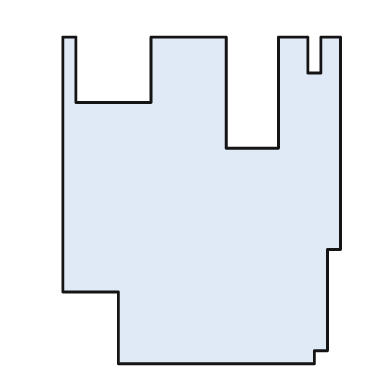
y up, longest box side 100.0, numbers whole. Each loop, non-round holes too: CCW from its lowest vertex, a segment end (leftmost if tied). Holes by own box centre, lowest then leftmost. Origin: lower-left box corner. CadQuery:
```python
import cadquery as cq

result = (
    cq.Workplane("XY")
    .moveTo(17.0, 0.0)
    .lineTo(77.0, 0.0)
    .lineTo(77.0, 4.0)
    .lineTo(81.0, 4.0)
    .lineTo(81.0, 35.0)
    .lineTo(85.0, 35.0)
    .lineTo(85.0, 100.0)
    .lineTo(79.0, 100.0)
    .lineTo(79.0, 89.0)
    .lineTo(75.0, 89.0)
    .lineTo(75.0, 100.0)
    .lineTo(66.0, 100.0)
    .lineTo(66.0, 66.0)
    .lineTo(50.0, 66.0)
    .lineTo(50.0, 100.0)
    .lineTo(27.0, 100.0)
    .lineTo(27.0, 80.0)
    .lineTo(4.0, 80.0)
    .lineTo(4.0, 100.0)
    .lineTo(0.0, 100.0)
    .lineTo(0.0, 22.0)
    .lineTo(17.0, 22.0)
    .close()
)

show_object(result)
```